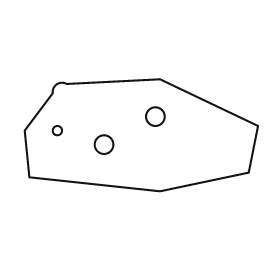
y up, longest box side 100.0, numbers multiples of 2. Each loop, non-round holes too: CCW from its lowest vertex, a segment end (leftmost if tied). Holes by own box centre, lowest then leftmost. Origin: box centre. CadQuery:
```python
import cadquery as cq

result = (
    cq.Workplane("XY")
    .moveTo(8.0, -24.0)
    .lineTo(46.0, -16.0)
    .lineTo(50.0, 4.0)
    .lineTo(8.0, 24.0)
    .lineTo(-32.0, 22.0)
    .threePointArc((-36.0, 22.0), (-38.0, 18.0))
    .lineTo(-50.0, 2.0)
    .lineTo(-48.0, -18.0)
    .close()
    .moveTo(-16.0, -4.0)
    .circle(4.0)
    .moveTo(-36.0, 2.0)
    .circle(2.0)
    .moveTo(6.0, 8.0)
    .circle(4.0)
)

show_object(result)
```